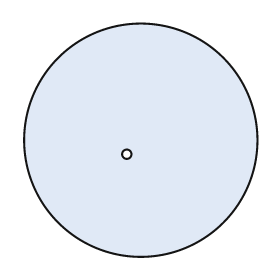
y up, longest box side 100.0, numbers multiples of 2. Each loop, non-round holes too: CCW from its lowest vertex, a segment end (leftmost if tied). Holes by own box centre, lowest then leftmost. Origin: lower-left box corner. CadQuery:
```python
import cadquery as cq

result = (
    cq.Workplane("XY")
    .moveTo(50.0, 50.0)
    .circle(50.0)
    .moveTo(44.0, 44.0)
    .circle(2.0)
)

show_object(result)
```